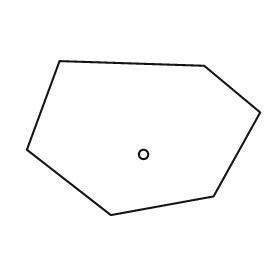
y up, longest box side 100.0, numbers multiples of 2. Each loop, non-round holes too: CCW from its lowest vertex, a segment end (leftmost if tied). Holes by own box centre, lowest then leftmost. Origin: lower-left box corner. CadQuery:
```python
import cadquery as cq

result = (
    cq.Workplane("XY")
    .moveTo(36.0, 0.0)
    .lineTo(80.0, 8.0)
    .lineTo(100.0, 44.0)
    .lineTo(76.0, 64.0)
    .lineTo(14.0, 66.0)
    .lineTo(0.0, 28.0)
    .close()
    .moveTo(50.0, 26.0)
    .circle(2.0)
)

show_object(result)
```